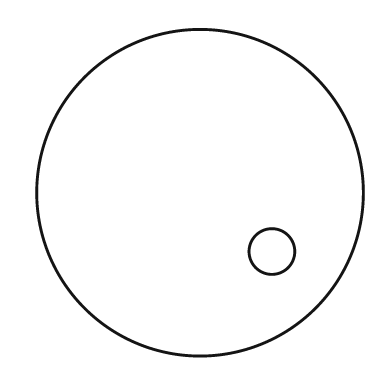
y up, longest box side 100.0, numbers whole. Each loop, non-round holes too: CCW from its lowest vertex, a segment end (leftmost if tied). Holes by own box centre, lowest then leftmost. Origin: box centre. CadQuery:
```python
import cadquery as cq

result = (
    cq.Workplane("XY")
    .moveTo(0.0, 0.0)
    .circle(50.0)
    .moveTo(22.0, -18.0)
    .circle(7.0)
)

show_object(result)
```